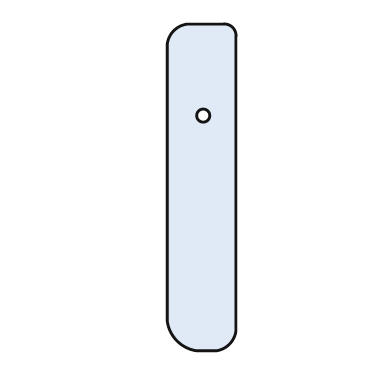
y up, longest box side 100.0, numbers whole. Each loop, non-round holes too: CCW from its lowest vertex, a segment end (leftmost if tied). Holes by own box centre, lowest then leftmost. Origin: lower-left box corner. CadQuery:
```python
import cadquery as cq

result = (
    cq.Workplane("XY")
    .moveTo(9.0, 0.0)
    .lineTo(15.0, 0.0)
    .threePointArc((19.0, 2.0), (21.0, 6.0))
    .lineTo(21.0, 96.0)
    .threePointArc((20.0, 99.0), (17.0, 100.0))
    .lineTo(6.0, 100.0)
    .threePointArc((2.0, 98.0), (0.0, 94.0))
    .lineTo(0.0, 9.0)
    .threePointArc((3.0, 3.0), (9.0, 0.0))
    .close()
    .moveTo(11.0, 72.0)
    .circle(2.0)
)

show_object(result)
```